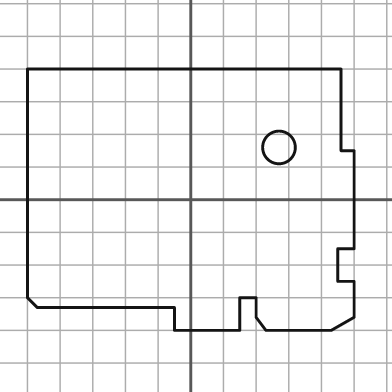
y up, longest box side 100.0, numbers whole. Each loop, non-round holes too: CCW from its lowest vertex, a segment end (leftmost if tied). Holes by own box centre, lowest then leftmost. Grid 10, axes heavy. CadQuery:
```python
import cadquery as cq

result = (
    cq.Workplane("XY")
    .moveTo(-5.0, -40.0)
    .lineTo(15.0, -40.0)
    .lineTo(15.0, -30.0)
    .lineTo(20.0, -30.0)
    .lineTo(20.0, -36.0)
    .lineTo(23.0, -40.0)
    .lineTo(43.0, -40.0)
    .lineTo(50.0, -36.0)
    .lineTo(50.0, -25.0)
    .lineTo(45.0, -25.0)
    .lineTo(45.0, -15.0)
    .lineTo(50.0, -15.0)
    .lineTo(50.0, 15.0)
    .lineTo(46.0, 15.0)
    .lineTo(46.0, 40.0)
    .lineTo(-50.0, 40.0)
    .lineTo(-50.0, -30.0)
    .lineTo(-47.0, -33.0)
    .lineTo(-5.0, -33.0)
    .close()
    .moveTo(27.0, 16.0)
    .circle(5.0)
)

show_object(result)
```